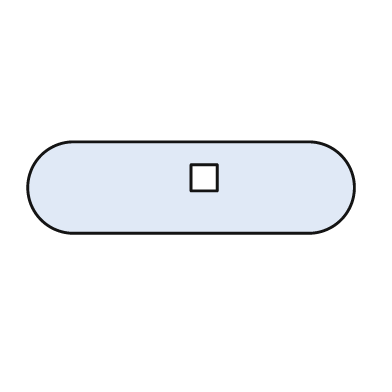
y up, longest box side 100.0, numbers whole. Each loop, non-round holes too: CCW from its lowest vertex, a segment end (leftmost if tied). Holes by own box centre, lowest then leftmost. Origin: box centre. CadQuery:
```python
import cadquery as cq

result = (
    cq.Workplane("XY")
    .moveTo(-36.0, -14.0)
    .lineTo(36.0, -14.0)
    .threePointArc((50.0, 0.0), (36.0, 14.0))
    .lineTo(-36.0, 14.0)
    .threePointArc((-50.0, 0.0), (-36.0, -14.0))
    .close()
    .moveTo(0.0, -1.0)
    .lineTo(8.0, -1.0)
    .lineTo(8.0, 7.0)
    .lineTo(0.0, 7.0)
    .close()
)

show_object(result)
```